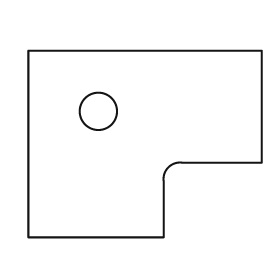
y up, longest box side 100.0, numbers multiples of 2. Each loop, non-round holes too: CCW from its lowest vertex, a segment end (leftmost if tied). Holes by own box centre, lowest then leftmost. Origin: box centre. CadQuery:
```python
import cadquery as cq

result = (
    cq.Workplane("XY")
    .moveTo(-50.0, -40.0)
    .lineTo(8.0, -40.0)
    .lineTo(8.0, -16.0)
    .threePointArc((10.0, -10.0), (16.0, -8.0))
    .lineTo(50.0, -8.0)
    .lineTo(50.0, 40.0)
    .lineTo(-50.0, 40.0)
    .close()
    .moveTo(-20.0, 14.0)
    .circle(8.0)
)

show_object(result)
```